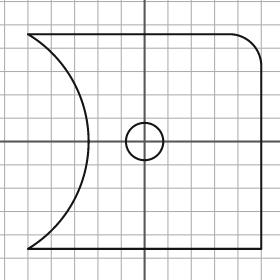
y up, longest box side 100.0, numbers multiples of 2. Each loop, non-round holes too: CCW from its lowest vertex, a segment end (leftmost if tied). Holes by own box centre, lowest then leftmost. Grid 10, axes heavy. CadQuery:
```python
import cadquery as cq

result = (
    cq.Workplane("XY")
    .moveTo(-50.0, -46.0)
    .lineTo(50.0, -46.0)
    .lineTo(50.0, 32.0)
    .threePointArc((46.0, 42.0), (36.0, 46.0))
    .lineTo(-50.0, 46.0)
    .threePointArc((-24.0, 0.0), (-50.0, -46.0))
    .close()
    .moveTo(0.0, 0.0)
    .circle(8.0)
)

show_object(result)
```